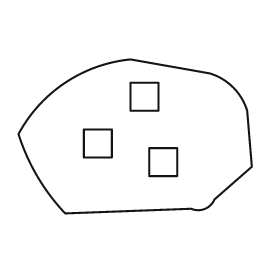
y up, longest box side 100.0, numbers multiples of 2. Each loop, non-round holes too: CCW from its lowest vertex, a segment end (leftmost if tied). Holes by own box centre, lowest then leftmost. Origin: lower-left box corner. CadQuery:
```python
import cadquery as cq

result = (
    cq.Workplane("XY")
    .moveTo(20.0, 0.0)
    .lineTo(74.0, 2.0)
    .threePointArc((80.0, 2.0), (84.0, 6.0))
    .lineTo(100.0, 20.0)
    .lineTo(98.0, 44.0)
    .threePointArc((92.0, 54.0), (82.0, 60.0))
    .lineTo(48.0, 66.0)
    .threePointArc((20.0, 56.0), (0.0, 34.0))
    .threePointArc((8.0, 16.0), (20.0, 0.0))
    .close()
    .moveTo(56.0, 16.0)
    .lineTo(68.0, 16.0)
    .lineTo(68.0, 28.0)
    .lineTo(56.0, 28.0)
    .close()
    .moveTo(28.0, 24.0)
    .lineTo(40.0, 24.0)
    .lineTo(40.0, 36.0)
    .lineTo(28.0, 36.0)
    .close()
    .moveTo(48.0, 44.0)
    .lineTo(60.0, 44.0)
    .lineTo(60.0, 56.0)
    .lineTo(48.0, 56.0)
    .close()
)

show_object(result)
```